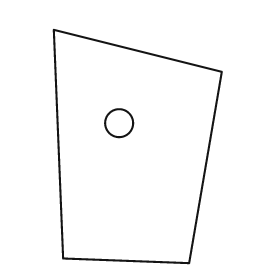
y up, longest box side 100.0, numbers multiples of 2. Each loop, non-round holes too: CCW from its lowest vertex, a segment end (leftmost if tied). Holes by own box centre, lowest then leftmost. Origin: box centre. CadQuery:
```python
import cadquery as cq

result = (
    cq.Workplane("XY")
    .moveTo(22.0, -50.0)
    .lineTo(36.0, 32.0)
    .lineTo(-36.0, 50.0)
    .lineTo(-32.0, -48.0)
    .close()
    .moveTo(-8.0, 10.0)
    .circle(6.0)
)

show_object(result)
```